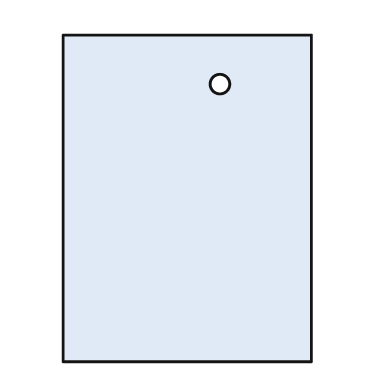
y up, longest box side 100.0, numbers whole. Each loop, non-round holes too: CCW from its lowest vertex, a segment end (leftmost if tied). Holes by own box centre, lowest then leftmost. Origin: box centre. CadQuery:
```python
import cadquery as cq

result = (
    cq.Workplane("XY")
    .moveTo(-38.0, -50.0)
    .lineTo(38.0, -50.0)
    .lineTo(38.0, 50.0)
    .lineTo(-38.0, 50.0)
    .close()
    .moveTo(10.0, 35.0)
    .circle(3.0)
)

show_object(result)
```